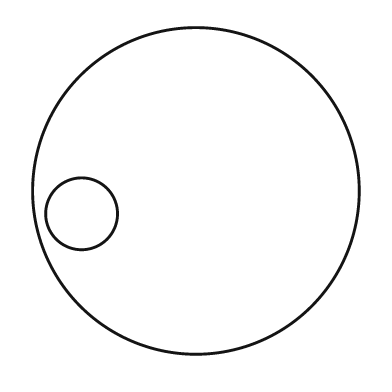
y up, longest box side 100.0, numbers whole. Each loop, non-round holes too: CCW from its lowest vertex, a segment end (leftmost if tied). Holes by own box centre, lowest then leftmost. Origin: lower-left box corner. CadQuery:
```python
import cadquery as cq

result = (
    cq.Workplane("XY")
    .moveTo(50.0, 50.0)
    .circle(50.0)
    .moveTo(15.0, 43.0)
    .circle(11.0)
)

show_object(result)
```